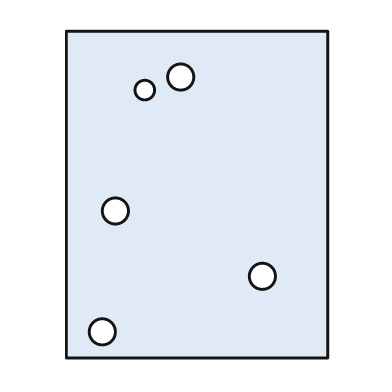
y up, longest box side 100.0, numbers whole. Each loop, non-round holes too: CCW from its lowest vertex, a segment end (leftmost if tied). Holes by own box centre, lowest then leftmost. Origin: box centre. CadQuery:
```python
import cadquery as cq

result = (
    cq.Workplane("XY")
    .moveTo(-40.0, -50.0)
    .lineTo(40.0, -50.0)
    .lineTo(40.0, 50.0)
    .lineTo(-40.0, 50.0)
    .close()
    .moveTo(-29.0, -42.0)
    .circle(4.0)
    .moveTo(20.0, -25.0)
    .circle(4.0)
    .moveTo(-25.0, -5.0)
    .circle(4.0)
    .moveTo(-16.0, 32.0)
    .circle(3.0)
    .moveTo(-5.0, 36.0)
    .circle(4.0)
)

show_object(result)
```